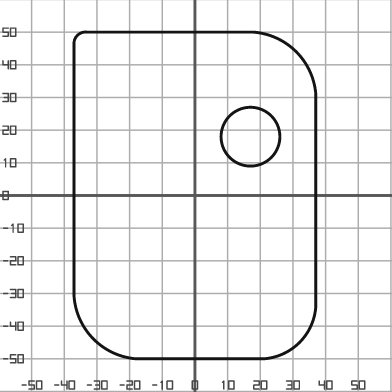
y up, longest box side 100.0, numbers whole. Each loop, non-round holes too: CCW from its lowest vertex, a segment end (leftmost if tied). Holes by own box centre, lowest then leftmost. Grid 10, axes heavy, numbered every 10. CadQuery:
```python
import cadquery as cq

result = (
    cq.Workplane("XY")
    .moveTo(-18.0, -50.0)
    .lineTo(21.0, -50.0)
    .threePointArc((32.0, -45.0), (37.0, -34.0))
    .lineTo(37.0, 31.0)
    .threePointArc((31.0, 44.0), (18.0, 50.0))
    .lineTo(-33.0, 50.0)
    .threePointArc((-36.0, 49.0), (-37.0, 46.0))
    .lineTo(-37.0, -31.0)
    .threePointArc((-31.0, -44.0), (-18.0, -50.0))
    .close()
    .moveTo(17.0, 18.0)
    .circle(9.0)
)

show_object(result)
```